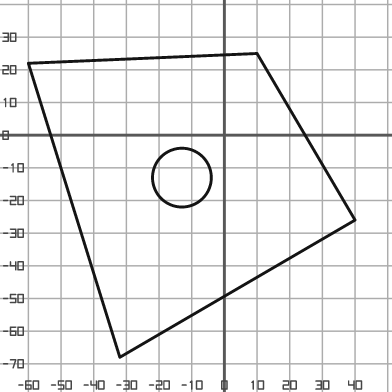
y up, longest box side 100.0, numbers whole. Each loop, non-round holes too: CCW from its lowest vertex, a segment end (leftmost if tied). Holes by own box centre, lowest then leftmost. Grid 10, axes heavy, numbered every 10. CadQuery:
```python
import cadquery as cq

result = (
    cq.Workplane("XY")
    .moveTo(-32.0, -68.0)
    .lineTo(40.0, -26.0)
    .lineTo(10.0, 25.0)
    .lineTo(-60.0, 22.0)
    .close()
    .moveTo(-13.0, -13.0)
    .circle(9.0)
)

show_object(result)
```